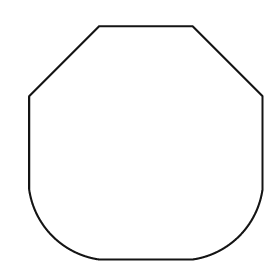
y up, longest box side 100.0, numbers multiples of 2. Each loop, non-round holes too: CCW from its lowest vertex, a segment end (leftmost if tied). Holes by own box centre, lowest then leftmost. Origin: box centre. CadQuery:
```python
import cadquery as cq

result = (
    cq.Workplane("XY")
    .moveTo(-20.0, -50.0)
    .lineTo(20.0, -50.0)
    .threePointArc((40.0, -40.0), (50.0, -20.0))
    .lineTo(50.0, 20.0)
    .lineTo(20.0, 50.0)
    .lineTo(-20.0, 50.0)
    .lineTo(-50.0, 20.0)
    .lineTo(-50.0, -20.0)
    .threePointArc((-40.0, -40.0), (-20.0, -50.0))
    .close()
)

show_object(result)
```